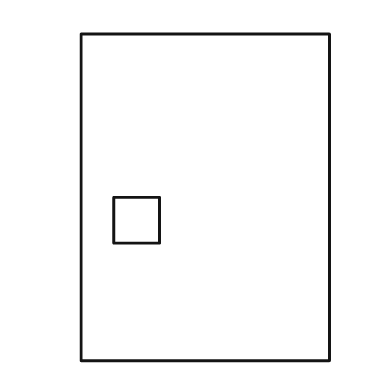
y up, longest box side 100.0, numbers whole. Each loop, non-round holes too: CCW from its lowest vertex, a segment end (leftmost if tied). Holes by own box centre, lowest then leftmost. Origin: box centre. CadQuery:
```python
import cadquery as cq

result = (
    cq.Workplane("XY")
    .moveTo(-38.0, -50.0)
    .lineTo(38.0, -50.0)
    .lineTo(38.0, 50.0)
    .lineTo(-38.0, 50.0)
    .close()
    .moveTo(-28.0, -14.0)
    .lineTo(-14.0, -14.0)
    .lineTo(-14.0, 0.0)
    .lineTo(-28.0, 0.0)
    .close()
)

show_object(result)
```